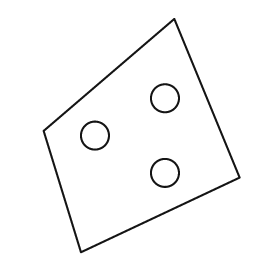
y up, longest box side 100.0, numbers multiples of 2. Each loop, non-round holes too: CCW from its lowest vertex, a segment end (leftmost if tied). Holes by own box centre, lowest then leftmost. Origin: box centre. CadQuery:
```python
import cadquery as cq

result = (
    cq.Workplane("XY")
    .moveTo(-26.0, -50.0)
    .lineTo(42.0, -18.0)
    .lineTo(14.0, 50.0)
    .lineTo(-42.0, 2.0)
    .close()
    .moveTo(10.0, -16.0)
    .circle(6.0)
    .moveTo(-20.0, 0.0)
    .circle(6.0)
    .moveTo(10.0, 16.0)
    .circle(6.0)
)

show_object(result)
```